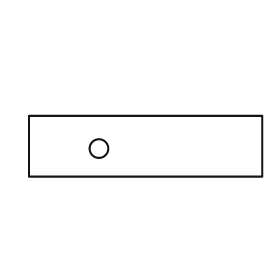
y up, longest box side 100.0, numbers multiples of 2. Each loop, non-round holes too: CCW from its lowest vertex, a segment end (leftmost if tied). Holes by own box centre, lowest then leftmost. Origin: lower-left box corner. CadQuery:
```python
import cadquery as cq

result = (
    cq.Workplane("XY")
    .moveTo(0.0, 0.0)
    .lineTo(100.0, 0.0)
    .lineTo(100.0, 26.0)
    .lineTo(0.0, 26.0)
    .close()
    .moveTo(30.0, 12.0)
    .circle(4.0)
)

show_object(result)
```